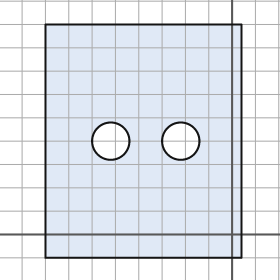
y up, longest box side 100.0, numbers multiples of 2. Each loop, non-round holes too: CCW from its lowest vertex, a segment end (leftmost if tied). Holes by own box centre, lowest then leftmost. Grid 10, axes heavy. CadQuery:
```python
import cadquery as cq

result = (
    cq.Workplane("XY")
    .moveTo(-80.0, -10.0)
    .lineTo(4.0, -10.0)
    .lineTo(4.0, 90.0)
    .lineTo(-80.0, 90.0)
    .close()
    .moveTo(-52.0, 40.0)
    .circle(8.0)
    .moveTo(-22.0, 40.0)
    .circle(8.0)
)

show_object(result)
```